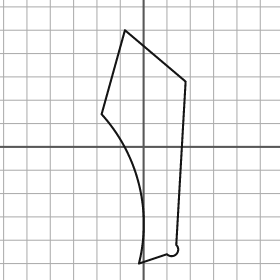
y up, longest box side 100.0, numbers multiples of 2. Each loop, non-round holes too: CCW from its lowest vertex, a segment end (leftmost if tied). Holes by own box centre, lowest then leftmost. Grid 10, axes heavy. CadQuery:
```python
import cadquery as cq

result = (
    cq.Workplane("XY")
    .moveTo(-2.0, -50.0)
    .lineTo(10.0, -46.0)
    .threePointArc((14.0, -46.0), (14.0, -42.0))
    .lineTo(18.0, 28.0)
    .lineTo(-8.0, 50.0)
    .lineTo(-18.0, 14.0)
    .threePointArc((-2.0, -16.0), (-2.0, -50.0))
    .close()
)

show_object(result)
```